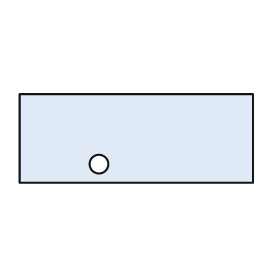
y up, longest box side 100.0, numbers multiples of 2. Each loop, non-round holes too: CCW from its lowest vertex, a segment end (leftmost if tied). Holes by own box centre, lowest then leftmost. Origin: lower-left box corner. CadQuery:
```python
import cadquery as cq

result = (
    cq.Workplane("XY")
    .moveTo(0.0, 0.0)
    .lineTo(100.0, 0.0)
    .lineTo(100.0, 38.0)
    .lineTo(0.0, 38.0)
    .close()
    .moveTo(34.0, 8.0)
    .circle(4.0)
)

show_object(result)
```